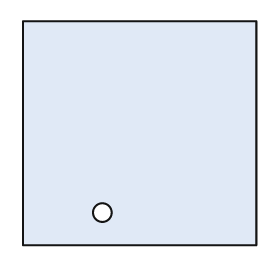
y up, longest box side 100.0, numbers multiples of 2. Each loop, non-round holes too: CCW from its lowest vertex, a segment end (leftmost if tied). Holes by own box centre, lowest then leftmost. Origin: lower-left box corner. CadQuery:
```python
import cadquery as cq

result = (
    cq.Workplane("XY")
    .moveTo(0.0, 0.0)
    .lineTo(100.0, 0.0)
    .lineTo(100.0, 96.0)
    .lineTo(0.0, 96.0)
    .close()
    .moveTo(34.0, 14.0)
    .circle(4.0)
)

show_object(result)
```